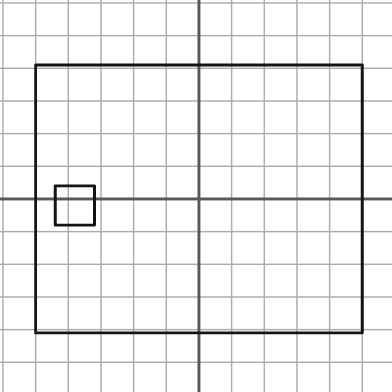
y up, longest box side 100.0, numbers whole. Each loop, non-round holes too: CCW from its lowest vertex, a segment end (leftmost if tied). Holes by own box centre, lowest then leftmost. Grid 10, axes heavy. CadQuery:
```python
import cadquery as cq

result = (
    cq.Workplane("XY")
    .moveTo(-50.0, -41.0)
    .lineTo(50.0, -41.0)
    .lineTo(50.0, 41.0)
    .lineTo(-50.0, 41.0)
    .close()
    .moveTo(-44.0, -8.0)
    .lineTo(-32.0, -8.0)
    .lineTo(-32.0, 4.0)
    .lineTo(-44.0, 4.0)
    .close()
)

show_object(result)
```